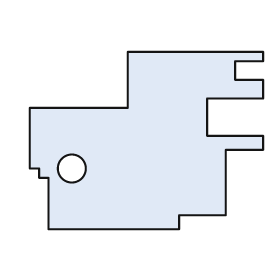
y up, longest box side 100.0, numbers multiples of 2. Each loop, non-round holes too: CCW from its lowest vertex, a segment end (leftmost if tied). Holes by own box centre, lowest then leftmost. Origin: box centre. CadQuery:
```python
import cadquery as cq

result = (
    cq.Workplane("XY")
    .moveTo(-42.0, -38.0)
    .lineTo(14.0, -38.0)
    .lineTo(14.0, -32.0)
    .lineTo(34.0, -32.0)
    .lineTo(34.0, -4.0)
    .lineTo(50.0, -4.0)
    .lineTo(50.0, 2.0)
    .lineTo(26.0, 2.0)
    .lineTo(26.0, 18.0)
    .lineTo(50.0, 18.0)
    .lineTo(50.0, 26.0)
    .lineTo(38.0, 26.0)
    .lineTo(38.0, 34.0)
    .lineTo(50.0, 34.0)
    .lineTo(50.0, 38.0)
    .lineTo(-8.0, 38.0)
    .lineTo(-8.0, 14.0)
    .lineTo(-50.0, 14.0)
    .lineTo(-50.0, -12.0)
    .lineTo(-46.0, -12.0)
    .lineTo(-46.0, -16.0)
    .lineTo(-42.0, -16.0)
    .close()
    .moveTo(-32.0, -12.0)
    .circle(6.0)
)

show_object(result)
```